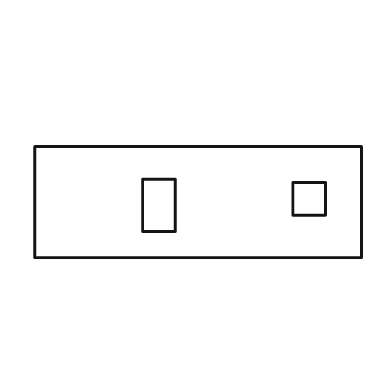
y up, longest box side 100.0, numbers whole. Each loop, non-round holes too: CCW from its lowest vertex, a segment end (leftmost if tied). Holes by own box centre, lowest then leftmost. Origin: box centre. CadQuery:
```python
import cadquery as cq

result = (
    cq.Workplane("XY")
    .moveTo(-50.0, -17.0)
    .lineTo(50.0, -17.0)
    .lineTo(50.0, 17.0)
    .lineTo(-50.0, 17.0)
    .close()
    .moveTo(-17.0, -9.0)
    .lineTo(-7.0, -9.0)
    .lineTo(-7.0, 7.0)
    .lineTo(-17.0, 7.0)
    .close()
    .moveTo(29.0, -4.0)
    .lineTo(39.0, -4.0)
    .lineTo(39.0, 6.0)
    .lineTo(29.0, 6.0)
    .close()
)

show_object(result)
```